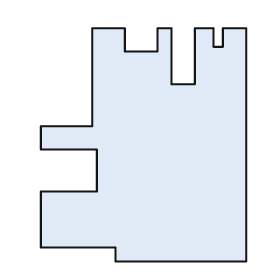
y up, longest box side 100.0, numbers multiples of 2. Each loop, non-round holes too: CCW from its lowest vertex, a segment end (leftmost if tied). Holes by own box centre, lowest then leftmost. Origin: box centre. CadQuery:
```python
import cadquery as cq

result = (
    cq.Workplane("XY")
    .moveTo(-12.0, -50.0)
    .lineTo(44.0, -50.0)
    .lineTo(44.0, 50.0)
    .lineTo(34.0, 50.0)
    .lineTo(34.0, 42.0)
    .lineTo(30.0, 42.0)
    .lineTo(30.0, 50.0)
    .lineTo(22.0, 50.0)
    .lineTo(22.0, 26.0)
    .lineTo(12.0, 26.0)
    .lineTo(12.0, 50.0)
    .lineTo(6.0, 50.0)
    .lineTo(6.0, 40.0)
    .lineTo(-8.0, 40.0)
    .lineTo(-8.0, 50.0)
    .lineTo(-22.0, 50.0)
    .lineTo(-22.0, 8.0)
    .lineTo(-44.0, 8.0)
    .lineTo(-44.0, -2.0)
    .lineTo(-20.0, -2.0)
    .lineTo(-20.0, -20.0)
    .lineTo(-44.0, -20.0)
    .lineTo(-44.0, -44.0)
    .lineTo(-12.0, -44.0)
    .close()
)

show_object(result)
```